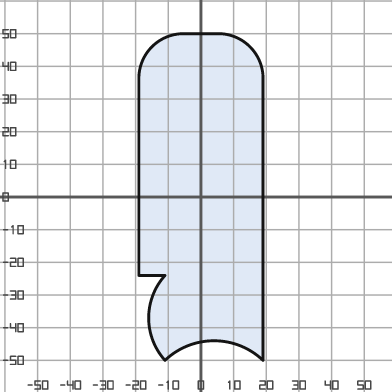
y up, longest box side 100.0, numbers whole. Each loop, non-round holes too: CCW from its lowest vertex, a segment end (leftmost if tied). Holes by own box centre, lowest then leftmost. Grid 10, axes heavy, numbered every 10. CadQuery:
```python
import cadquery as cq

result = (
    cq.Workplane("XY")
    .moveTo(-11.0, -50.0)
    .threePointArc((4.0, -44.0), (19.0, -50.0))
    .lineTo(19.0, 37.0)
    .threePointArc((15.0, 46.0), (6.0, 50.0))
    .lineTo(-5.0, 50.0)
    .threePointArc((-15.0, 46.0), (-19.0, 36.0))
    .lineTo(-19.0, -24.0)
    .lineTo(-11.0, -24.0)
    .threePointArc((-16.0, -37.0), (-11.0, -50.0))
    .close()
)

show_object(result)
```